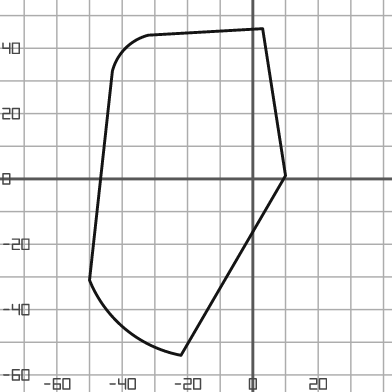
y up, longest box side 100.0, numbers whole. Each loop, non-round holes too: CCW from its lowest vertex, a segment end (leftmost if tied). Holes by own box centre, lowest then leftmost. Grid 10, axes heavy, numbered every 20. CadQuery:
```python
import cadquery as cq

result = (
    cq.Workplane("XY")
    .moveTo(-22.0, -54.0)
    .lineTo(10.0, 1.0)
    .lineTo(3.0, 46.0)
    .lineTo(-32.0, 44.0)
    .threePointArc((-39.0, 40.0), (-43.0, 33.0))
    .lineTo(-50.0, -31.0)
    .threePointArc((-39.0, -46.0), (-22.0, -54.0))
    .close()
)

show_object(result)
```